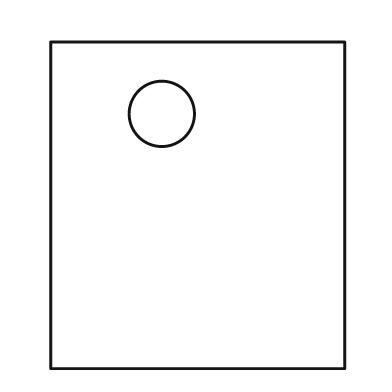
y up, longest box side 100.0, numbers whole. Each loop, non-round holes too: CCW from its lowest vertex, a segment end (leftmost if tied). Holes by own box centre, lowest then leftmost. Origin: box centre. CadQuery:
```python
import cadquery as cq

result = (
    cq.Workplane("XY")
    .moveTo(-45.0, -50.0)
    .lineTo(45.0, -50.0)
    .lineTo(45.0, 50.0)
    .lineTo(-45.0, 50.0)
    .close()
    .moveTo(-11.0, 28.0)
    .circle(10.0)
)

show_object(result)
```